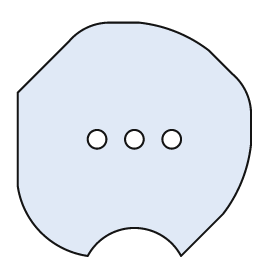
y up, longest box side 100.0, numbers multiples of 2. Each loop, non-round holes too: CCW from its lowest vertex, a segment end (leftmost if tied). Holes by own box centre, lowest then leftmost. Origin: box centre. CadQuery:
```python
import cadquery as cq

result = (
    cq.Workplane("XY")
    .moveTo(-20.0, -50.0)
    .threePointArc((0.0, -38.0), (20.0, -50.0))
    .lineTo(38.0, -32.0)
    .threePointArc((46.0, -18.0), (50.0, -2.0))
    .lineTo(50.0, 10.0)
    .threePointArc((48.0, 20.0), (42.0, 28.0))
    .lineTo(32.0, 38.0)
    .threePointArc((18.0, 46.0), (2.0, 50.0))
    .lineTo(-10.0, 50.0)
    .threePointArc((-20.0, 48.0), (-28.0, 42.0))
    .lineTo(-50.0, 20.0)
    .lineTo(-50.0, -20.0)
    .threePointArc((-40.0, -40.0), (-20.0, -50.0))
    .close()
    .moveTo(-16.0, 0.0)
    .circle(4.0)
    .moveTo(0.0, 0.0)
    .circle(4.0)
    .moveTo(16.0, 0.0)
    .circle(4.0)
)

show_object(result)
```